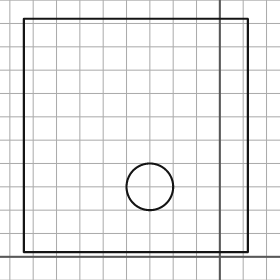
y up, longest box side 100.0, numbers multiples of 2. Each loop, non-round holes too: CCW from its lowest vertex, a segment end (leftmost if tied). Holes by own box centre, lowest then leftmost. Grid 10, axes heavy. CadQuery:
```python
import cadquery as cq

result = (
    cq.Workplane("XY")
    .moveTo(-84.0, 2.0)
    .lineTo(12.0, 2.0)
    .lineTo(12.0, 102.0)
    .lineTo(-84.0, 102.0)
    .close()
    .moveTo(-30.0, 30.0)
    .circle(10.0)
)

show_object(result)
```